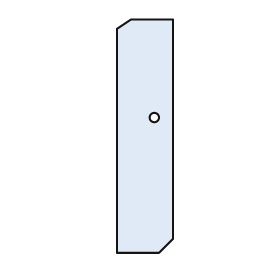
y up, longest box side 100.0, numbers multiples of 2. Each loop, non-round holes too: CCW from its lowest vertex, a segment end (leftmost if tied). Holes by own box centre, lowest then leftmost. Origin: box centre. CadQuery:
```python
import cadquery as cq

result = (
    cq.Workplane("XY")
    .moveTo(-12.0, -50.0)
    .lineTo(6.0, -50.0)
    .lineTo(12.0, -44.0)
    .lineTo(12.0, 50.0)
    .lineTo(-6.0, 50.0)
    .lineTo(-12.0, 46.0)
    .close()
    .moveTo(4.0, 8.0)
    .circle(2.0)
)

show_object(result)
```